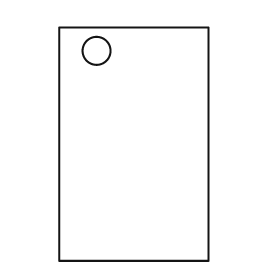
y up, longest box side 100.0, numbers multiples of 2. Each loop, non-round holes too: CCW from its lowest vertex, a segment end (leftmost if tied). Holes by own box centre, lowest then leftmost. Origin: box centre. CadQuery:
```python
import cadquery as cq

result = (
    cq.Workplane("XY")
    .moveTo(-32.0, -50.0)
    .lineTo(32.0, -50.0)
    .lineTo(32.0, 50.0)
    .lineTo(-32.0, 50.0)
    .close()
    .moveTo(-16.0, 40.0)
    .circle(6.0)
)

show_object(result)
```